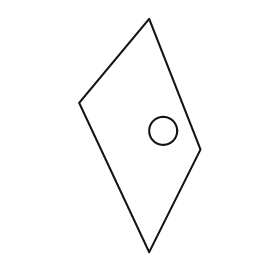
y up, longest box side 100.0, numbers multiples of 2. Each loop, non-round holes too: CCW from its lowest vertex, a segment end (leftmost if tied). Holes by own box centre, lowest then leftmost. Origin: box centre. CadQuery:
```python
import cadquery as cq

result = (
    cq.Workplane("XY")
    .moveTo(4.0, -50.0)
    .lineTo(26.0, -6.0)
    .lineTo(4.0, 50.0)
    .lineTo(-26.0, 14.0)
    .close()
    .moveTo(10.0, 2.0)
    .circle(6.0)
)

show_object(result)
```